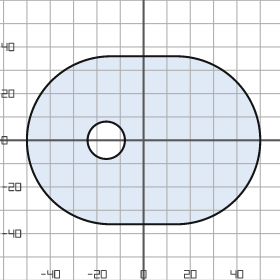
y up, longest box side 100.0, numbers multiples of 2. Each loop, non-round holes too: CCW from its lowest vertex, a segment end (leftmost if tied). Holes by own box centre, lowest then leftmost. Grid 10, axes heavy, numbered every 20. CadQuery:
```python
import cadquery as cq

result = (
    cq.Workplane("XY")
    .moveTo(-14.0, -36.0)
    .lineTo(14.0, -36.0)
    .threePointArc((50.0, 0.0), (14.0, 36.0))
    .lineTo(-14.0, 36.0)
    .threePointArc((-50.0, 0.0), (-14.0, -36.0))
    .close()
    .moveTo(-16.0, 0.0)
    .circle(8.0)
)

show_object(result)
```